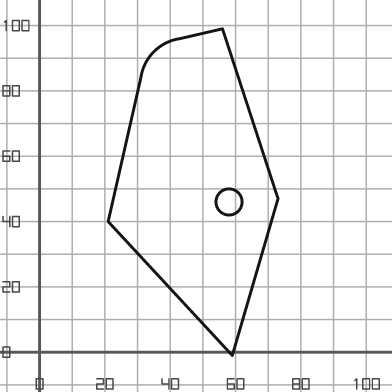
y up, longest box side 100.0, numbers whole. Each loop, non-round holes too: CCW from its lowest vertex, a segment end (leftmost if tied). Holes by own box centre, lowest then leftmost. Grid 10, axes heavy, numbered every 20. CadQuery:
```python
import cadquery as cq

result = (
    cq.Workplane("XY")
    .moveTo(59.0, -1.0)
    .lineTo(73.0, 47.0)
    .lineTo(56.0, 99.0)
    .lineTo(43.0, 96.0)
    .threePointArc((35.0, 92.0), (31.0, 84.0))
    .lineTo(21.0, 40.0)
    .close()
    .moveTo(58.0, 46.0)
    .circle(4.0)
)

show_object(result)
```